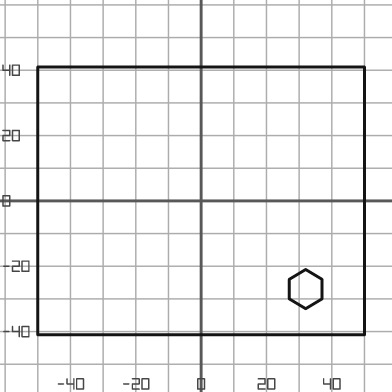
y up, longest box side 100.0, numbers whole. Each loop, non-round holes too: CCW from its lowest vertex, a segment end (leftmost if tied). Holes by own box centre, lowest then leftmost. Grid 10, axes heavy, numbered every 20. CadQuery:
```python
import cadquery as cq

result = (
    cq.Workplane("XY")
    .moveTo(-50.0, -41.0)
    .lineTo(50.0, -41.0)
    .lineTo(50.0, 41.0)
    .lineTo(-50.0, 41.0)
    .close()
    .moveTo(32.0, -33.0)
    .lineTo(37.0, -30.0)
    .lineTo(37.0, -24.0)
    .lineTo(32.0, -21.0)
    .lineTo(27.0, -24.0)
    .lineTo(27.0, -30.0)
    .close()
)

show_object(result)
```